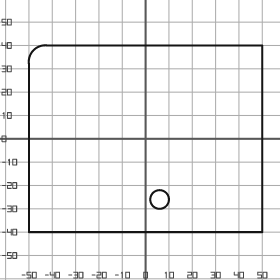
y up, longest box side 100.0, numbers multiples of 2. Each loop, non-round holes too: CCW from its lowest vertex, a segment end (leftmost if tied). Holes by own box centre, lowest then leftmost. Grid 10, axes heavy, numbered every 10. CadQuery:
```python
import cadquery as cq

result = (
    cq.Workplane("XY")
    .moveTo(-50.0, -40.0)
    .lineTo(50.0, -40.0)
    .lineTo(50.0, 40.0)
    .lineTo(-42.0, 40.0)
    .threePointArc((-48.0, 38.0), (-50.0, 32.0))
    .close()
    .moveTo(6.0, -26.0)
    .circle(4.0)
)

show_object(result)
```